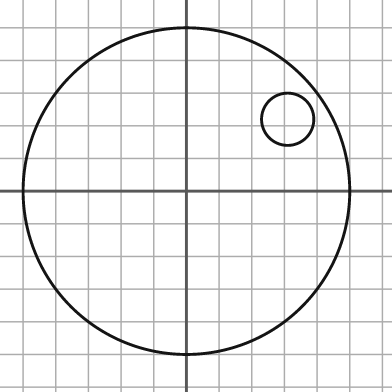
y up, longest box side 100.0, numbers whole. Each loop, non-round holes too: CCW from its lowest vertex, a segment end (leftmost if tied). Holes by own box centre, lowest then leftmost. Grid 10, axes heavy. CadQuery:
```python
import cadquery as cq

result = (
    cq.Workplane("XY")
    .moveTo(0.0, 0.0)
    .circle(50.0)
    .moveTo(31.0, 22.0)
    .circle(8.0)
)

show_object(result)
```